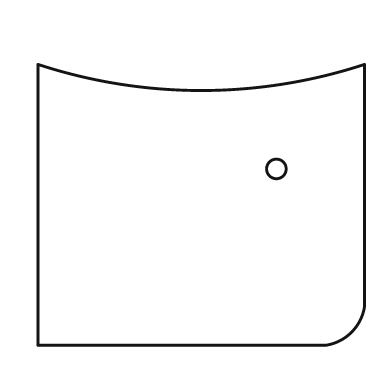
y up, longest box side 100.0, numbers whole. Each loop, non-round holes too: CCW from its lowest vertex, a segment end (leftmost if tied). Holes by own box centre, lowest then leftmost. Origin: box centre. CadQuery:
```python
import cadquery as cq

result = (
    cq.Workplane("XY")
    .moveTo(-50.0, -43.0)
    .lineTo(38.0, -43.0)
    .threePointArc((46.0, -39.0), (50.0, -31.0))
    .lineTo(50.0, 43.0)
    .threePointArc((0.0, 35.0), (-50.0, 43.0))
    .close()
    .moveTo(23.0, 11.0)
    .circle(3.0)
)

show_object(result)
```